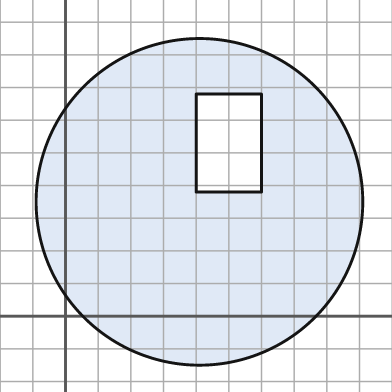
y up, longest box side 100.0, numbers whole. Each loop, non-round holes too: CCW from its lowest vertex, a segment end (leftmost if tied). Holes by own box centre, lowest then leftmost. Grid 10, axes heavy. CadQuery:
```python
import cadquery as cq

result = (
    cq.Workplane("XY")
    .moveTo(41.0, 35.0)
    .circle(50.0)
    .moveTo(40.0, 38.0)
    .lineTo(60.0, 38.0)
    .lineTo(60.0, 68.0)
    .lineTo(40.0, 68.0)
    .close()
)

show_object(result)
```